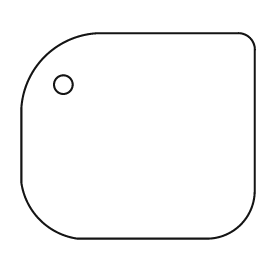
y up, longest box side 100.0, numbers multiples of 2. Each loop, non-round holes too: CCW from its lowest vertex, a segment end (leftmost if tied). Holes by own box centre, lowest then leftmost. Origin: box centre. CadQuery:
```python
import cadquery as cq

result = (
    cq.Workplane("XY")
    .moveTo(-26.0, -44.0)
    .lineTo(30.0, -44.0)
    .threePointArc((44.0, -38.0), (50.0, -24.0))
    .lineTo(50.0, 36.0)
    .threePointArc((48.0, 42.0), (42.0, 44.0))
    .lineTo(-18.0, 44.0)
    .threePointArc((-40.0, 34.0), (-50.0, 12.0))
    .lineTo(-50.0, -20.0)
    .threePointArc((-42.0, -36.0), (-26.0, -44.0))
    .close()
    .moveTo(-32.0, 22.0)
    .circle(4.0)
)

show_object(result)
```